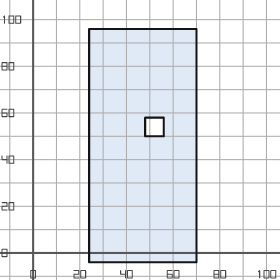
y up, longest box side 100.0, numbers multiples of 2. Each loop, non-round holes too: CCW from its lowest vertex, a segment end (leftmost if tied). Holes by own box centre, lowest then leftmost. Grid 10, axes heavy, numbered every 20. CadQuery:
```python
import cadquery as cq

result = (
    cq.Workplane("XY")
    .moveTo(24.0, -4.0)
    .lineTo(70.0, -4.0)
    .lineTo(70.0, 96.0)
    .lineTo(24.0, 96.0)
    .close()
    .moveTo(48.0, 50.0)
    .lineTo(56.0, 50.0)
    .lineTo(56.0, 58.0)
    .lineTo(48.0, 58.0)
    .close()
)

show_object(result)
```